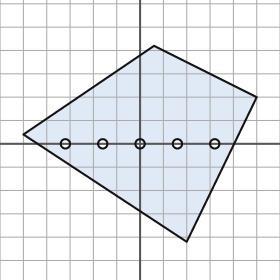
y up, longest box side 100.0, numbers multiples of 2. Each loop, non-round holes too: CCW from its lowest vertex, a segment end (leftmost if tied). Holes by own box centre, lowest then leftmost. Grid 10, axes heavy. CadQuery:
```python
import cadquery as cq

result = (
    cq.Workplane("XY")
    .moveTo(20.0, -42.0)
    .lineTo(50.0, 20.0)
    .lineTo(6.0, 42.0)
    .lineTo(-50.0, 4.0)
    .close()
    .moveTo(-32.0, 0.0)
    .circle(2.0)
    .moveTo(-16.0, 0.0)
    .circle(2.0)
    .moveTo(0.0, 0.0)
    .circle(2.0)
    .moveTo(16.0, 0.0)
    .circle(2.0)
    .moveTo(32.0, 0.0)
    .circle(2.0)
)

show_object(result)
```